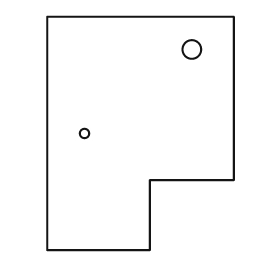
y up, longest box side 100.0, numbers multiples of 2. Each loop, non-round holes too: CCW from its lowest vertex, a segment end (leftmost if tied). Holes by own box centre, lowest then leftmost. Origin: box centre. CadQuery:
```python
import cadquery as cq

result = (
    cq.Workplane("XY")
    .moveTo(-40.0, -50.0)
    .lineTo(4.0, -50.0)
    .lineTo(4.0, -20.0)
    .lineTo(40.0, -20.0)
    .lineTo(40.0, 50.0)
    .lineTo(-40.0, 50.0)
    .close()
    .moveTo(-24.0, 0.0)
    .circle(2.0)
    .moveTo(22.0, 36.0)
    .circle(4.0)
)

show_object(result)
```